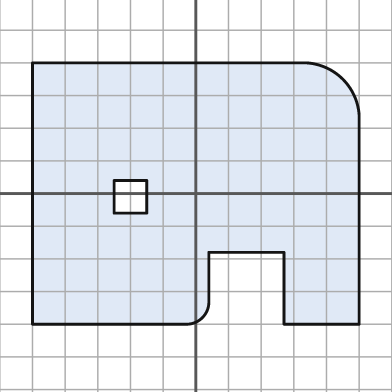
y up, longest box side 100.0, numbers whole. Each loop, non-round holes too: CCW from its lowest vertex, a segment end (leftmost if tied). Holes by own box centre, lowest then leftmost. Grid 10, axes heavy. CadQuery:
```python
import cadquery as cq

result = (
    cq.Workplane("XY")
    .moveTo(-50.0, -40.0)
    .lineTo(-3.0, -40.0)
    .threePointArc((2.0, -38.0), (4.0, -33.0))
    .lineTo(4.0, -18.0)
    .lineTo(27.0, -18.0)
    .lineTo(27.0, -40.0)
    .lineTo(50.0, -40.0)
    .lineTo(50.0, 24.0)
    .threePointArc((45.0, 35.0), (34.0, 40.0))
    .lineTo(-50.0, 40.0)
    .close()
    .moveTo(-25.0, -6.0)
    .lineTo(-15.0, -6.0)
    .lineTo(-15.0, 4.0)
    .lineTo(-25.0, 4.0)
    .close()
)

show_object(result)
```